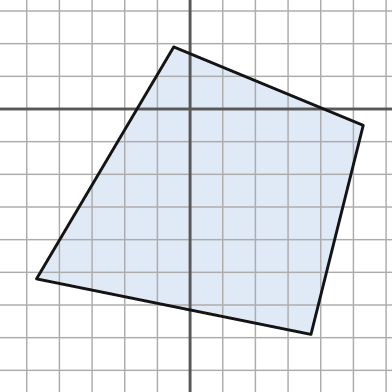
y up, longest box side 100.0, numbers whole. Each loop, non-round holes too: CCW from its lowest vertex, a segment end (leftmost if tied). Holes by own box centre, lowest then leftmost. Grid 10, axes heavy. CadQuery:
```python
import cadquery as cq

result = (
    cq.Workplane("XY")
    .moveTo(37.0, -69.0)
    .lineTo(53.0, -5.0)
    .lineTo(-5.0, 19.0)
    .lineTo(-47.0, -52.0)
    .close()
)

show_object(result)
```